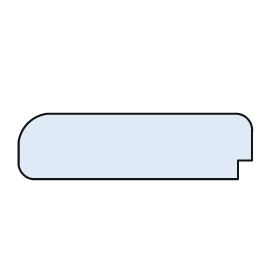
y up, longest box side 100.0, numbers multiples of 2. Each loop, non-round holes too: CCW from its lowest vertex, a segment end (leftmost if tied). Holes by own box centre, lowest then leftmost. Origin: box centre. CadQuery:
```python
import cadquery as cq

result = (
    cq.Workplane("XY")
    .moveTo(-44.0, -14.0)
    .lineTo(44.0, -14.0)
    .lineTo(44.0, -6.0)
    .lineTo(50.0, -6.0)
    .lineTo(50.0, 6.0)
    .threePointArc((48.0, 12.0), (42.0, 14.0))
    .lineTo(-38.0, 14.0)
    .threePointArc((-46.0, 10.0), (-50.0, 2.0))
    .lineTo(-50.0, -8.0)
    .threePointArc((-48.0, -12.0), (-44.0, -14.0))
    .close()
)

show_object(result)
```